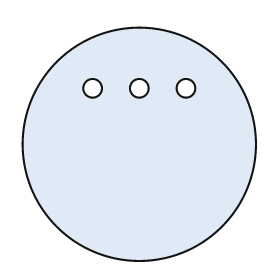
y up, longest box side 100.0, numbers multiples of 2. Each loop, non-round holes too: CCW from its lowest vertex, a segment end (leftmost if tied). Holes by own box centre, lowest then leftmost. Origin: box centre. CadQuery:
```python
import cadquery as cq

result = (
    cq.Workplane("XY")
    .moveTo(0.0, 0.0)
    .circle(50.0)
    .moveTo(-20.0, 24.0)
    .circle(4.0)
    .moveTo(0.0, 24.0)
    .circle(4.0)
    .moveTo(20.0, 24.0)
    .circle(4.0)
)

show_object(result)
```